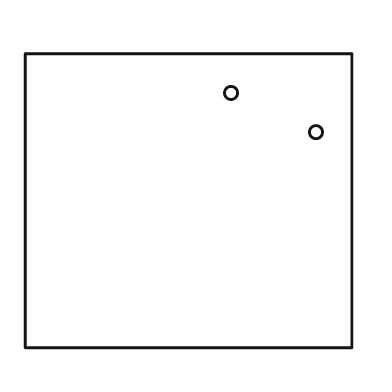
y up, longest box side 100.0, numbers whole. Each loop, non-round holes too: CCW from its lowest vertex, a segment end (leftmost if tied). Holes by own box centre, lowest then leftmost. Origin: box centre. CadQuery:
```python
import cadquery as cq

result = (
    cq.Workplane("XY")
    .moveTo(-50.0, -45.0)
    .lineTo(50.0, -45.0)
    .lineTo(50.0, 45.0)
    .lineTo(-50.0, 45.0)
    .close()
    .moveTo(39.0, 21.0)
    .circle(2.0)
    .moveTo(13.0, 33.0)
    .circle(2.0)
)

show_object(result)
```